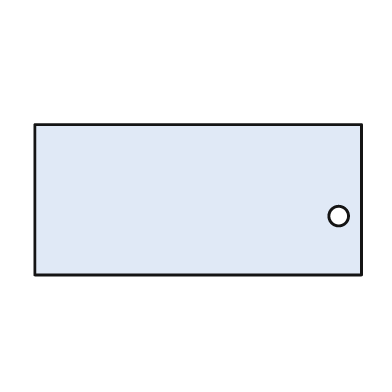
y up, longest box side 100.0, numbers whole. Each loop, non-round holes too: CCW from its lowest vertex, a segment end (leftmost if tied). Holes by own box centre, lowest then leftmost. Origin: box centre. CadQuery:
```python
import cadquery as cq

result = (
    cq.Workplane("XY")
    .moveTo(-50.0, -23.0)
    .lineTo(50.0, -23.0)
    .lineTo(50.0, 23.0)
    .lineTo(-50.0, 23.0)
    .close()
    .moveTo(43.0, -5.0)
    .circle(3.0)
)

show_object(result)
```